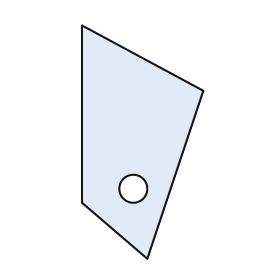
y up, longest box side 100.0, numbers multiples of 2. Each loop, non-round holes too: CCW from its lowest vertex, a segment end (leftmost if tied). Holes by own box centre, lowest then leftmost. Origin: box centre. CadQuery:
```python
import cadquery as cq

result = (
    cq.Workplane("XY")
    .moveTo(2.0, -50.0)
    .lineTo(26.0, 22.0)
    .lineTo(-26.0, 50.0)
    .lineTo(-26.0, -26.0)
    .close()
    .moveTo(-4.0, -20.0)
    .circle(6.0)
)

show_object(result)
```